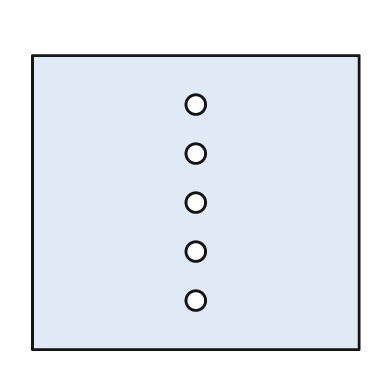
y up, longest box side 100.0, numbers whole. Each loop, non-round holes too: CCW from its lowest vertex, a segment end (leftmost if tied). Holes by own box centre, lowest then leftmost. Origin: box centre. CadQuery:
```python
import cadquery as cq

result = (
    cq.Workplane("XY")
    .moveTo(-50.0, -45.0)
    .lineTo(50.0, -45.0)
    .lineTo(50.0, 45.0)
    .lineTo(-50.0, 45.0)
    .close()
    .moveTo(0.0, -30.0)
    .circle(3.0)
    .moveTo(0.0, -15.0)
    .circle(3.0)
    .moveTo(0.0, 0.0)
    .circle(3.0)
    .moveTo(0.0, 15.0)
    .circle(3.0)
    .moveTo(0.0, 30.0)
    .circle(3.0)
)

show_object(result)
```